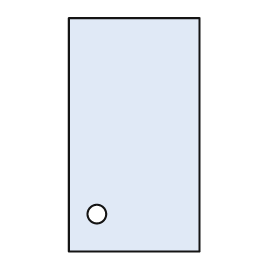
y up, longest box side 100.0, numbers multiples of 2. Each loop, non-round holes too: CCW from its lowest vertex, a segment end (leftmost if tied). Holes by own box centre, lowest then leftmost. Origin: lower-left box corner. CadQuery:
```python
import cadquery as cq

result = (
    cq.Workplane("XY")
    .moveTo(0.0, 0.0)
    .lineTo(56.0, 0.0)
    .lineTo(56.0, 100.0)
    .lineTo(0.0, 100.0)
    .close()
    .moveTo(12.0, 16.0)
    .circle(4.0)
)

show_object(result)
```